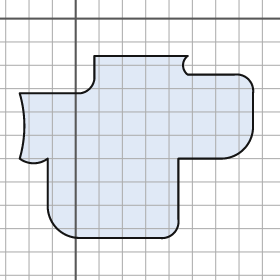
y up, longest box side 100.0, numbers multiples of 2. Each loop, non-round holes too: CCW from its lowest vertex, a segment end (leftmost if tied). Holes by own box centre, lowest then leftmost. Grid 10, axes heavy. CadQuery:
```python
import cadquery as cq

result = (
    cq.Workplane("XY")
    .moveTo(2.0, -94.0)
    .lineTo(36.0, -94.0)
    .threePointArc((42.0, -92.0), (44.0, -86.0))
    .lineTo(44.0, -60.0)
    .lineTo(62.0, -60.0)
    .threePointArc((72.0, -56.0), (76.0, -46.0))
    .lineTo(76.0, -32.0)
    .threePointArc((74.0, -26.0), (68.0, -24.0))
    .lineTo(48.0, -24.0)
    .threePointArc((46.0, -20.0), (48.0, -16.0))
    .lineTo(8.0, -16.0)
    .lineTo(8.0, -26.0)
    .threePointArc((6.0, -30.0), (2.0, -32.0))
    .lineTo(-24.0, -32.0)
    .threePointArc((-22.0, -46.0), (-24.0, -60.0))
    .threePointArc((-18.0, -62.0), (-12.0, -60.0))
    .lineTo(-12.0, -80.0)
    .threePointArc((-8.0, -90.0), (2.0, -94.0))
    .close()
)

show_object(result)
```